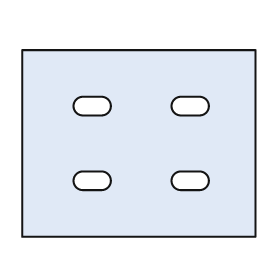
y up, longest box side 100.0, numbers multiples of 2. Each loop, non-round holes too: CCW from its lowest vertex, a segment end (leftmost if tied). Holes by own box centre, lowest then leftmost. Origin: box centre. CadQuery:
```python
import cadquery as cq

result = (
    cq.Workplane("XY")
    .moveTo(-50.0, -40.0)
    .lineTo(50.0, -40.0)
    .lineTo(50.0, 40.0)
    .lineTo(-50.0, 40.0)
    .close()
    .moveTo(-24.0, -20.0)
    .lineTo(-16.0, -20.0)
    .threePointArc((-12.0, -16.0), (-16.0, -12.0))
    .lineTo(-24.0, -12.0)
    .threePointArc((-28.0, -16.0), (-24.0, -20.0))
    .close()
    .moveTo(18.0, -20.0)
    .lineTo(26.0, -20.0)
    .threePointArc((30.0, -16.0), (26.0, -12.0))
    .lineTo(18.0, -12.0)
    .threePointArc((14.0, -16.0), (18.0, -20.0))
    .close()
    .moveTo(-24.0, 12.0)
    .lineTo(-16.0, 12.0)
    .threePointArc((-12.0, 16.0), (-16.0, 20.0))
    .lineTo(-24.0, 20.0)
    .threePointArc((-28.0, 16.0), (-24.0, 12.0))
    .close()
    .moveTo(18.0, 12.0)
    .lineTo(26.0, 12.0)
    .threePointArc((30.0, 16.0), (26.0, 20.0))
    .lineTo(18.0, 20.0)
    .threePointArc((14.0, 16.0), (18.0, 12.0))
    .close()
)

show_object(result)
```